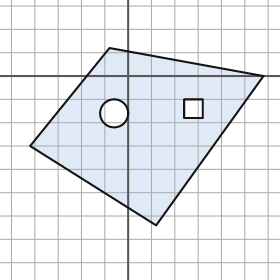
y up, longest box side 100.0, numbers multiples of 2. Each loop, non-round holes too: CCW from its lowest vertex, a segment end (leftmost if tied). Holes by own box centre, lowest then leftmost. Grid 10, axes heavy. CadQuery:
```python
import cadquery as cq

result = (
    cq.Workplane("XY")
    .moveTo(12.0, -64.0)
    .lineTo(58.0, 0.0)
    .lineTo(-8.0, 12.0)
    .lineTo(-42.0, -30.0)
    .close()
    .moveTo(-6.0, -16.0)
    .circle(6.0)
    .moveTo(24.0, -18.0)
    .lineTo(32.0, -18.0)
    .lineTo(32.0, -10.0)
    .lineTo(24.0, -10.0)
    .close()
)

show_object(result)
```